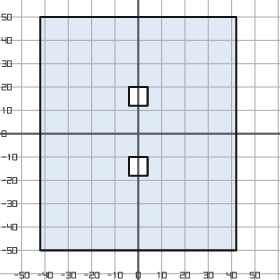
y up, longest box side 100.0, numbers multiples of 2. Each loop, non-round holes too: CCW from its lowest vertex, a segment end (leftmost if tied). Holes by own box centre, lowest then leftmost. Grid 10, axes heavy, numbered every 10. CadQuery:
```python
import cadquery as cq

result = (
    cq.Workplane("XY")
    .moveTo(-42.0, -50.0)
    .lineTo(42.0, -50.0)
    .lineTo(42.0, 50.0)
    .lineTo(-42.0, 50.0)
    .close()
    .moveTo(-4.0, -18.0)
    .lineTo(4.0, -18.0)
    .lineTo(4.0, -10.0)
    .lineTo(-4.0, -10.0)
    .close()
    .moveTo(-4.0, 12.0)
    .lineTo(4.0, 12.0)
    .lineTo(4.0, 20.0)
    .lineTo(-4.0, 20.0)
    .close()
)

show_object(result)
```